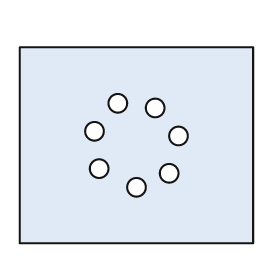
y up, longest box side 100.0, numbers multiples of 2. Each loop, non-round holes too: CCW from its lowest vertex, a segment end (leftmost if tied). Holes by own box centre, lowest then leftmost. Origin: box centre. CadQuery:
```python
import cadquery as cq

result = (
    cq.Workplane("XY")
    .moveTo(-50.0, -42.0)
    .lineTo(50.0, -42.0)
    .lineTo(50.0, 42.0)
    .lineTo(-50.0, 42.0)
    .close()
    .moveTo(0.0, -18.0)
    .circle(4.0)
    .moveTo(14.0, -12.0)
    .circle(4.0)
    .moveTo(-16.0, -10.0)
    .circle(4.0)
    .moveTo(18.0, 4.0)
    .circle(4.0)
    .moveTo(-18.0, 6.0)
    .circle(4.0)
    .moveTo(8.0, 16.0)
    .circle(4.0)
    .moveTo(-8.0, 18.0)
    .circle(4.0)
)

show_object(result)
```